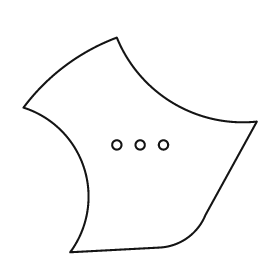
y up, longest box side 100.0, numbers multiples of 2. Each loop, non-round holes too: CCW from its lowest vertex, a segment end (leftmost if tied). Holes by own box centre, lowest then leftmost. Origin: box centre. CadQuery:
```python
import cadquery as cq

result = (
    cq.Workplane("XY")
    .moveTo(-30.0, -46.0)
    .lineTo(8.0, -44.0)
    .threePointArc((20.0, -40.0), (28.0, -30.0))
    .lineTo(50.0, 10.0)
    .threePointArc((14.0, 18.0), (-10.0, 46.0))
    .threePointArc((-32.0, 34.0), (-50.0, 16.0))
    .threePointArc((-24.0, -10.0), (-30.0, -46.0))
    .close()
    .moveTo(-10.0, 0.0)
    .circle(2.0)
    .moveTo(0.0, 0.0)
    .circle(2.0)
    .moveTo(10.0, 0.0)
    .circle(2.0)
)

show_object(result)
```